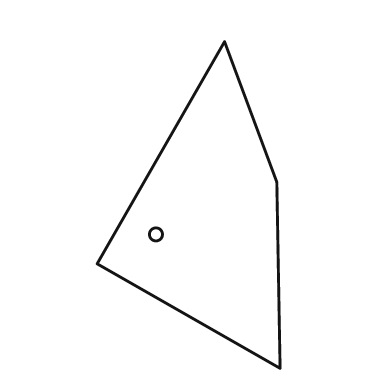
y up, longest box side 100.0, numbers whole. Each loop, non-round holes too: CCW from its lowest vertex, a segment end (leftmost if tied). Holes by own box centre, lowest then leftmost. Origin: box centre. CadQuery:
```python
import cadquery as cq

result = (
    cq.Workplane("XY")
    .moveTo(28.0, -50.0)
    .lineTo(27.0, 7.0)
    .lineTo(11.0, 50.0)
    .lineTo(-28.0, -18.0)
    .close()
    .moveTo(-10.0, -9.0)
    .circle(2.0)
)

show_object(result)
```